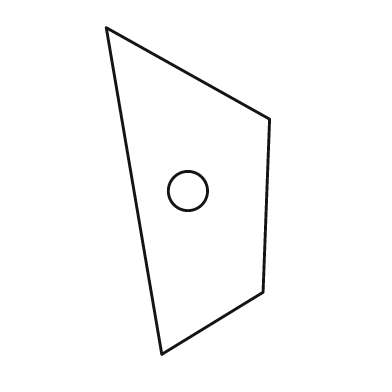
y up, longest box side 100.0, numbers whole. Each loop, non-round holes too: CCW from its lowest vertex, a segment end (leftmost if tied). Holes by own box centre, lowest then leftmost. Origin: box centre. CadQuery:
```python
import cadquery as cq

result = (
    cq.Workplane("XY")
    .moveTo(-8.0, -50.0)
    .lineTo(23.0, -31.0)
    .lineTo(25.0, 22.0)
    .lineTo(-25.0, 50.0)
    .close()
    .moveTo(0.0, 0.0)
    .circle(6.0)
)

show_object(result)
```